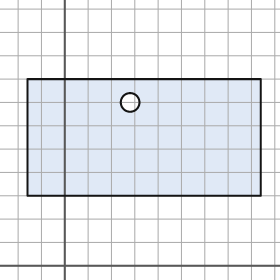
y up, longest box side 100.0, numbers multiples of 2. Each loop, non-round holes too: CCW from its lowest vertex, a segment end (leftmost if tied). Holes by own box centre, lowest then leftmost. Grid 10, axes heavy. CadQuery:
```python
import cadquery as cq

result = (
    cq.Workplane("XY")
    .moveTo(-16.0, 30.0)
    .lineTo(84.0, 30.0)
    .lineTo(84.0, 80.0)
    .lineTo(-16.0, 80.0)
    .close()
    .moveTo(28.0, 70.0)
    .circle(4.0)
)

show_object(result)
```